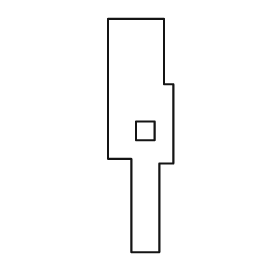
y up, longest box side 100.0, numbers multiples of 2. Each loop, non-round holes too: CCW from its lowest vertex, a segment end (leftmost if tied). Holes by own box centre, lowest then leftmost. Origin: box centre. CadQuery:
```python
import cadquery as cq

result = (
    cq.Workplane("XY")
    .moveTo(-4.0, -50.0)
    .lineTo(8.0, -50.0)
    .lineTo(8.0, -12.0)
    .lineTo(14.0, -12.0)
    .lineTo(14.0, 22.0)
    .lineTo(10.0, 22.0)
    .lineTo(10.0, 50.0)
    .lineTo(-14.0, 50.0)
    .lineTo(-14.0, -10.0)
    .lineTo(-4.0, -10.0)
    .close()
    .moveTo(-2.0, -2.0)
    .lineTo(6.0, -2.0)
    .lineTo(6.0, 6.0)
    .lineTo(-2.0, 6.0)
    .close()
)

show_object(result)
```